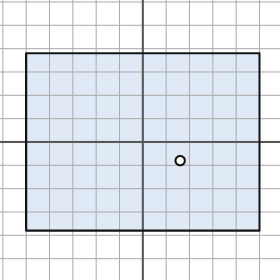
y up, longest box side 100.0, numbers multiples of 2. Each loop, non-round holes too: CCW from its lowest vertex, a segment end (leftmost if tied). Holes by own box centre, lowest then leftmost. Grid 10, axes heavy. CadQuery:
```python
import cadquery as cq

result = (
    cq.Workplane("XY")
    .moveTo(-50.0, -38.0)
    .lineTo(50.0, -38.0)
    .lineTo(50.0, 38.0)
    .lineTo(-50.0, 38.0)
    .close()
    .moveTo(16.0, -8.0)
    .circle(2.0)
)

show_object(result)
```